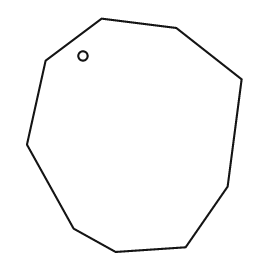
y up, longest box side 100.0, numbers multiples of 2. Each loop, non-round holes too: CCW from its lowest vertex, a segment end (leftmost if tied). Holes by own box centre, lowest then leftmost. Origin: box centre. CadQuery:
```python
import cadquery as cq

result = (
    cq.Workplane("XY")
    .moveTo(-8.0, -50.0)
    .lineTo(22.0, -48.0)
    .lineTo(40.0, -22.0)
    .lineTo(46.0, 24.0)
    .lineTo(18.0, 46.0)
    .lineTo(-14.0, 50.0)
    .lineTo(-38.0, 32.0)
    .lineTo(-46.0, -4.0)
    .lineTo(-26.0, -40.0)
    .close()
    .moveTo(-22.0, 34.0)
    .circle(2.0)
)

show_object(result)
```